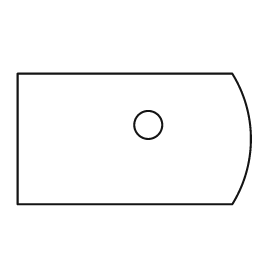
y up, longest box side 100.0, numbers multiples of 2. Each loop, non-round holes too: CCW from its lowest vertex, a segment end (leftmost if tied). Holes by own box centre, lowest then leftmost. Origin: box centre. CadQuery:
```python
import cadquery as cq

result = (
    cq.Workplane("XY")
    .moveTo(-50.0, -28.0)
    .lineTo(42.0, -28.0)
    .threePointArc((50.0, 0.0), (42.0, 28.0))
    .lineTo(-50.0, 28.0)
    .close()
    .moveTo(6.0, 6.0)
    .circle(6.0)
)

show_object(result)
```